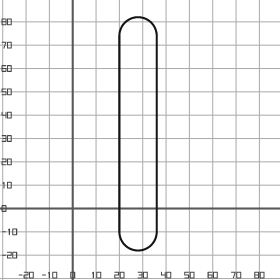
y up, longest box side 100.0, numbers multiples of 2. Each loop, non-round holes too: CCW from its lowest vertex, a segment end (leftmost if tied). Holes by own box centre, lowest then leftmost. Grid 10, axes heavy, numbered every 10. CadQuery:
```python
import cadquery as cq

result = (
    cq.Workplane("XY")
    .moveTo(20.0, -10.0)
    .threePointArc((28.0, -18.0), (36.0, -10.0))
    .lineTo(36.0, 74.0)
    .threePointArc((28.0, 82.0), (20.0, 74.0))
    .close()
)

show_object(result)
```